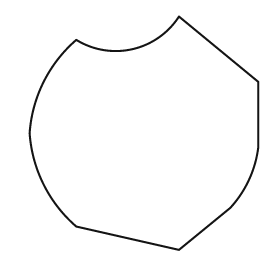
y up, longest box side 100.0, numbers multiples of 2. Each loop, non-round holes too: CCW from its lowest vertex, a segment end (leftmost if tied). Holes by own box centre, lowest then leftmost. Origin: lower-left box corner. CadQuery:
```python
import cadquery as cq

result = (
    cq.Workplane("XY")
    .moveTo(64.0, 0.0)
    .lineTo(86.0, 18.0)
    .threePointArc((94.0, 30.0), (98.0, 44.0))
    .lineTo(98.0, 72.0)
    .lineTo(64.0, 100.0)
    .threePointArc((44.0, 86.0), (20.0, 90.0))
    .threePointArc((6.0, 72.0), (0.0, 50.0))
    .threePointArc((6.0, 28.0), (20.0, 10.0))
    .close()
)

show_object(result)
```